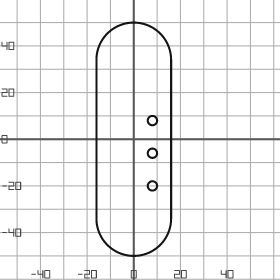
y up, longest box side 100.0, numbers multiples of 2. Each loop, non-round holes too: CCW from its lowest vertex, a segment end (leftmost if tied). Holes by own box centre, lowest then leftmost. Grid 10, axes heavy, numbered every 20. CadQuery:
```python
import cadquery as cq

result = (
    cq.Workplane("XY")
    .moveTo(-16.0, -34.0)
    .threePointArc((0.0, -50.0), (16.0, -34.0))
    .lineTo(16.0, 34.0)
    .threePointArc((0.0, 50.0), (-16.0, 34.0))
    .close()
    .moveTo(8.0, -20.0)
    .circle(2.0)
    .moveTo(8.0, -6.0)
    .circle(2.0)
    .moveTo(8.0, 8.0)
    .circle(2.0)
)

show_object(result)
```